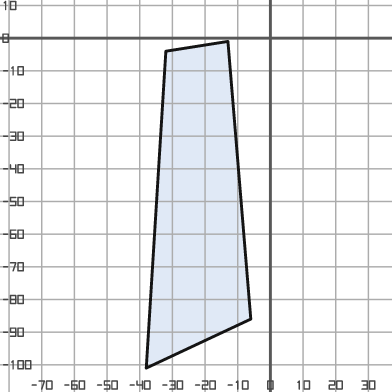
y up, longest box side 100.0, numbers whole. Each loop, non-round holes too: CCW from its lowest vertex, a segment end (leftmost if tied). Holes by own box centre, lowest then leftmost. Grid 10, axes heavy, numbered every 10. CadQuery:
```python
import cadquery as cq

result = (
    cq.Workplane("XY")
    .moveTo(-38.0, -101.0)
    .lineTo(-6.0, -86.0)
    .lineTo(-13.0, -1.0)
    .lineTo(-32.0, -4.0)
    .close()
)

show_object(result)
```